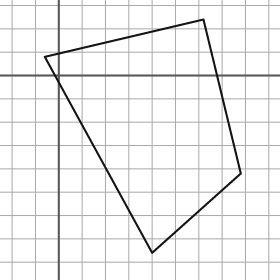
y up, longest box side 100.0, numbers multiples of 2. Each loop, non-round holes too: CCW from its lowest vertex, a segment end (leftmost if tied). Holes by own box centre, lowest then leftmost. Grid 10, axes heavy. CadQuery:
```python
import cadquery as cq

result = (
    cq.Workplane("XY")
    .moveTo(40.0, -76.0)
    .lineTo(78.0, -42.0)
    .lineTo(62.0, 24.0)
    .lineTo(-6.0, 8.0)
    .close()
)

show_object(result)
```